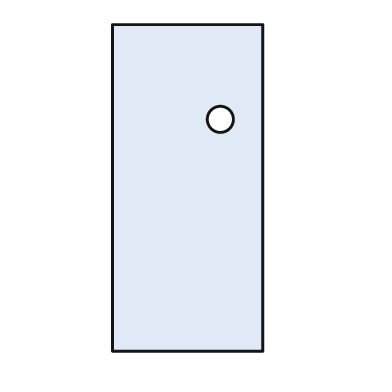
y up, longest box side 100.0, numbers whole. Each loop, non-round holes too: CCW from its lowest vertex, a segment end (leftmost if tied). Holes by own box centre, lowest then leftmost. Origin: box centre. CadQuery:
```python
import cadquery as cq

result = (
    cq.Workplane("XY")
    .moveTo(-23.0, -50.0)
    .lineTo(23.0, -50.0)
    .lineTo(23.0, 50.0)
    .lineTo(-23.0, 50.0)
    .close()
    .moveTo(10.0, 21.0)
    .circle(4.0)
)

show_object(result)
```